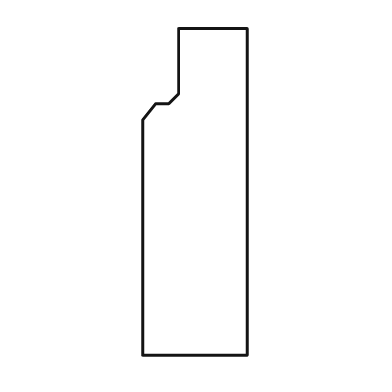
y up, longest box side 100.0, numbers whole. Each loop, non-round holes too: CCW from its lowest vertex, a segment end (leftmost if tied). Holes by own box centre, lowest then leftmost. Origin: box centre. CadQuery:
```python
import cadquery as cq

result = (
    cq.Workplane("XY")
    .moveTo(-16.0, -50.0)
    .lineTo(16.0, -50.0)
    .lineTo(16.0, 50.0)
    .lineTo(-5.0, 50.0)
    .lineTo(-5.0, 30.0)
    .lineTo(-8.0, 27.0)
    .lineTo(-12.0, 27.0)
    .lineTo(-16.0, 22.0)
    .close()
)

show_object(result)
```